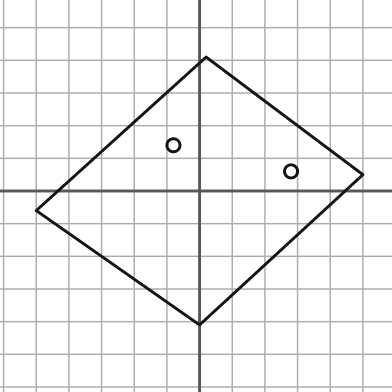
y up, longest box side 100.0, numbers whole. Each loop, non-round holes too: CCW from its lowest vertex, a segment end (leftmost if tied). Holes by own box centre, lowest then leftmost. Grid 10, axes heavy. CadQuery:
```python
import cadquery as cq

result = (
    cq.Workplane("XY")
    .moveTo(0.0, -41.0)
    .lineTo(50.0, 5.0)
    .lineTo(2.0, 41.0)
    .lineTo(-50.0, -6.0)
    .close()
    .moveTo(28.0, 6.0)
    .circle(2.0)
    .moveTo(-8.0, 14.0)
    .circle(2.0)
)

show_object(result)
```